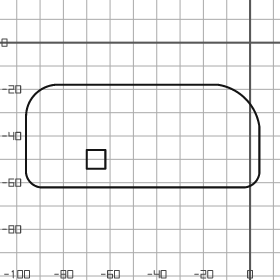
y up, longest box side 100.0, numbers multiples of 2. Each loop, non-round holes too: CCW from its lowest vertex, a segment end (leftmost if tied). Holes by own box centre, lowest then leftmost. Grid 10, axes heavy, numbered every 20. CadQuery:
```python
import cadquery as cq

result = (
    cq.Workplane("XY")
    .moveTo(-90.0, -62.0)
    .lineTo(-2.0, -62.0)
    .threePointArc((2.0, -60.0), (4.0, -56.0))
    .lineTo(4.0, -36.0)
    .threePointArc((-2.0, -24.0), (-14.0, -18.0))
    .lineTo(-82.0, -18.0)
    .threePointArc((-92.0, -22.0), (-96.0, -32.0))
    .lineTo(-96.0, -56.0)
    .threePointArc((-94.0, -60.0), (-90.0, -62.0))
    .close()
    .moveTo(-70.0, -54.0)
    .lineTo(-62.0, -54.0)
    .lineTo(-62.0, -46.0)
    .lineTo(-70.0, -46.0)
    .close()
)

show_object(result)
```